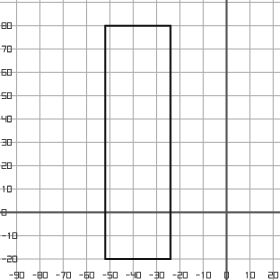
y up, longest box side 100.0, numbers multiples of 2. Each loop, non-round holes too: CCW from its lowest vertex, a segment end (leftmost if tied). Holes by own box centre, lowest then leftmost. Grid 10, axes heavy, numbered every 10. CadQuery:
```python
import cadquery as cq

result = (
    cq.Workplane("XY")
    .moveTo(-52.0, -20.0)
    .lineTo(-24.0, -20.0)
    .lineTo(-24.0, 80.0)
    .lineTo(-52.0, 80.0)
    .close()
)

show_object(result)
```